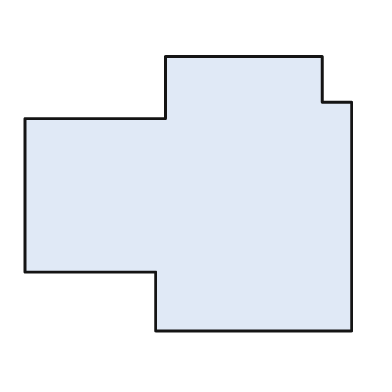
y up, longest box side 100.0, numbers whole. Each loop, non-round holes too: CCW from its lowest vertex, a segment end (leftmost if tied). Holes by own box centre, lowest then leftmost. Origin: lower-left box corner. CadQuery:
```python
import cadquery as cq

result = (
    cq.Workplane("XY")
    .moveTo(40.0, 0.0)
    .lineTo(100.0, 0.0)
    .lineTo(100.0, 70.0)
    .lineTo(91.0, 70.0)
    .lineTo(91.0, 84.0)
    .lineTo(43.0, 84.0)
    .lineTo(43.0, 65.0)
    .lineTo(0.0, 65.0)
    .lineTo(0.0, 18.0)
    .lineTo(40.0, 18.0)
    .close()
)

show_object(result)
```